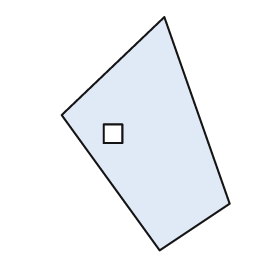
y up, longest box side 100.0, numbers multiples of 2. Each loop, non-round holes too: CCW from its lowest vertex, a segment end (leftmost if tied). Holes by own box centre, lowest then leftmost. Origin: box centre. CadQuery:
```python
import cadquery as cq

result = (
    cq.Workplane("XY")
    .moveTo(6.0, -50.0)
    .lineTo(36.0, -30.0)
    .lineTo(8.0, 50.0)
    .lineTo(-36.0, 8.0)
    .close()
    .moveTo(-18.0, -4.0)
    .lineTo(-10.0, -4.0)
    .lineTo(-10.0, 4.0)
    .lineTo(-18.0, 4.0)
    .close()
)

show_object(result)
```